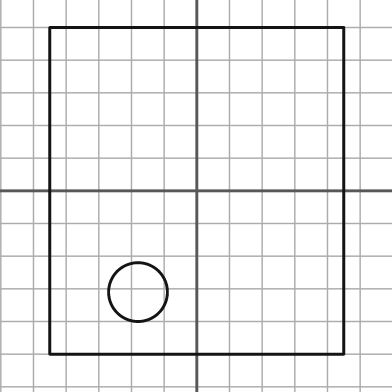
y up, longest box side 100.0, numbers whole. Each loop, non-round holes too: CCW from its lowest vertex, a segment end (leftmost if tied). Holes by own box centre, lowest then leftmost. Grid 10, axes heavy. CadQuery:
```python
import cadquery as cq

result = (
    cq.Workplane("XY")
    .moveTo(-45.0, -50.0)
    .lineTo(45.0, -50.0)
    .lineTo(45.0, 50.0)
    .lineTo(-45.0, 50.0)
    .close()
    .moveTo(-18.0, -31.0)
    .circle(9.0)
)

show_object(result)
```